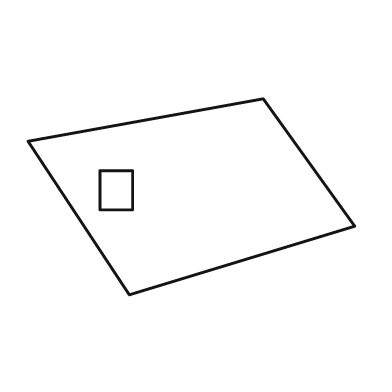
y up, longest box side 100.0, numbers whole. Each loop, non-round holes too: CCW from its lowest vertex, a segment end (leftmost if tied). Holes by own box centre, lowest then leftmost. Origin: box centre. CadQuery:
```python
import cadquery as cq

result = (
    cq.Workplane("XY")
    .moveTo(-19.0, -30.0)
    .lineTo(50.0, -9.0)
    .lineTo(22.0, 30.0)
    .lineTo(-50.0, 17.0)
    .close()
    .moveTo(-28.0, -4.0)
    .lineTo(-18.0, -4.0)
    .lineTo(-18.0, 8.0)
    .lineTo(-28.0, 8.0)
    .close()
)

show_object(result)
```